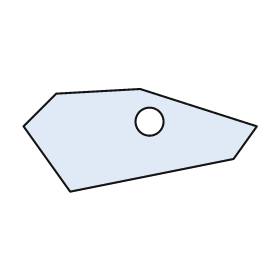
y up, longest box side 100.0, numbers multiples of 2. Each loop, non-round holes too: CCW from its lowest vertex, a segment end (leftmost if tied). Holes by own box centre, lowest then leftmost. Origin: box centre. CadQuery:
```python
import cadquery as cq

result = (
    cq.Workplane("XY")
    .moveTo(-30.0, -22.0)
    .lineTo(40.0, -8.0)
    .lineTo(50.0, 6.0)
    .lineTo(0.0, 22.0)
    .lineTo(-36.0, 20.0)
    .lineTo(-50.0, 6.0)
    .close()
    .moveTo(4.0, 8.0)
    .circle(6.0)
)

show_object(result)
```